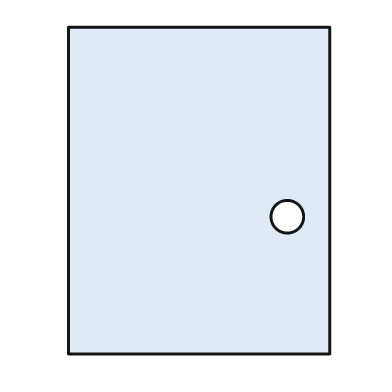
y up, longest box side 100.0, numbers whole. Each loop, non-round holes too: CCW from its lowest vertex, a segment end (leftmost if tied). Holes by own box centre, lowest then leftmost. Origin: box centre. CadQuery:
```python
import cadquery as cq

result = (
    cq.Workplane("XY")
    .moveTo(-40.0, -50.0)
    .lineTo(40.0, -50.0)
    .lineTo(40.0, 50.0)
    .lineTo(-40.0, 50.0)
    .close()
    .moveTo(27.0, -8.0)
    .circle(5.0)
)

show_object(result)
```